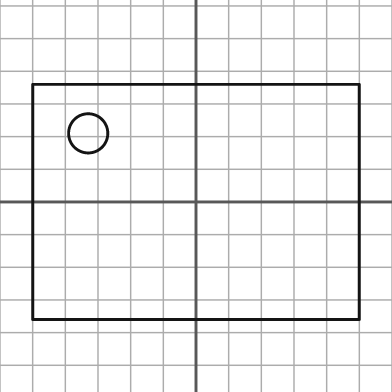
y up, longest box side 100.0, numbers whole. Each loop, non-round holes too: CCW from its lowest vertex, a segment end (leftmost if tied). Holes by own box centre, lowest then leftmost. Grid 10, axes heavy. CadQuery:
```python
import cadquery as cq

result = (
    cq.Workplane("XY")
    .moveTo(-50.0, -36.0)
    .lineTo(50.0, -36.0)
    .lineTo(50.0, 36.0)
    .lineTo(-50.0, 36.0)
    .close()
    .moveTo(-33.0, 21.0)
    .circle(6.0)
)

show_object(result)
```